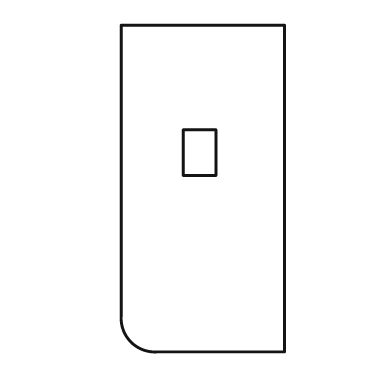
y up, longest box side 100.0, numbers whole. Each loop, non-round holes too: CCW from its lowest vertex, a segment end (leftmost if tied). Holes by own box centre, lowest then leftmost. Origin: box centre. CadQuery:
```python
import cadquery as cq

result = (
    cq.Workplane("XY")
    .moveTo(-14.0, -50.0)
    .lineTo(25.0, -50.0)
    .lineTo(25.0, 50.0)
    .lineTo(-25.0, 50.0)
    .lineTo(-25.0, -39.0)
    .threePointArc((-22.0, -47.0), (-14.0, -50.0))
    .close()
    .moveTo(-6.0, 4.0)
    .lineTo(4.0, 4.0)
    .lineTo(4.0, 18.0)
    .lineTo(-6.0, 18.0)
    .close()
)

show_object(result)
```